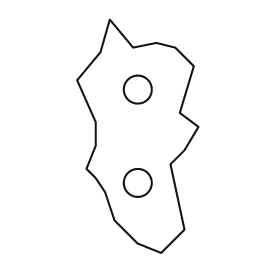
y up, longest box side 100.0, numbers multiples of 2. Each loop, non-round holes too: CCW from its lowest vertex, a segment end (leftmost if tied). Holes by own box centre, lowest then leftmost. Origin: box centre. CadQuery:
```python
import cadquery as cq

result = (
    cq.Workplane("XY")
    .moveTo(10.0, -50.0)
    .lineTo(20.0, -40.0)
    .lineTo(14.0, -12.0)
    .lineTo(20.0, -6.0)
    .lineTo(26.0, 4.0)
    .lineTo(18.0, 10.0)
    .lineTo(24.0, 30.0)
    .lineTo(16.0, 38.0)
    .lineTo(8.0, 40.0)
    .lineTo(-2.0, 38.0)
    .lineTo(-12.0, 50.0)
    .lineTo(-16.0, 36.0)
    .lineTo(-26.0, 24.0)
    .lineTo(-18.0, 6.0)
    .lineTo(-18.0, -4.0)
    .lineTo(-22.0, -14.0)
    .lineTo(-18.0, -18.0)
    .lineTo(-14.0, -24.0)
    .lineTo(-10.0, -36.0)
    .lineTo(0.0, -46.0)
    .close()
    .moveTo(0.0, -20.0)
    .circle(6.0)
    .moveTo(0.0, 20.0)
    .circle(6.0)
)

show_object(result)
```